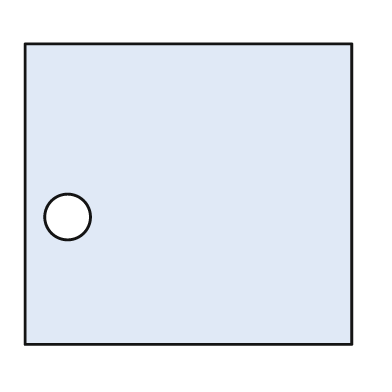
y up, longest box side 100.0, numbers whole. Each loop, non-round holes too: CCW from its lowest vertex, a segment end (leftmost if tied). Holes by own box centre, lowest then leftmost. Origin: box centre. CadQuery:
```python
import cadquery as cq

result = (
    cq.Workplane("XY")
    .moveTo(-50.0, -46.0)
    .lineTo(50.0, -46.0)
    .lineTo(50.0, 46.0)
    .lineTo(-50.0, 46.0)
    .close()
    .moveTo(-37.0, -7.0)
    .circle(7.0)
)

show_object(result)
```